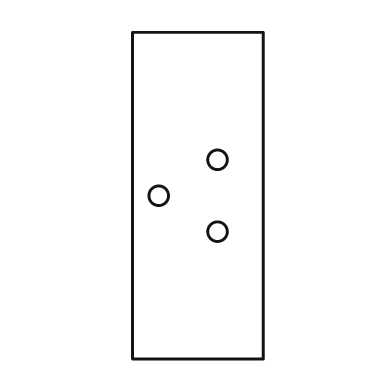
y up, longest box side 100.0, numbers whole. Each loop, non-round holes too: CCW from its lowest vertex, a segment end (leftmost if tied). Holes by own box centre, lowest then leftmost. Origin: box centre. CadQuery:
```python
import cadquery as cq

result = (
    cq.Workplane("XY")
    .moveTo(-20.0, -50.0)
    .lineTo(20.0, -50.0)
    .lineTo(20.0, 50.0)
    .lineTo(-20.0, 50.0)
    .close()
    .moveTo(6.0, -11.0)
    .circle(3.0)
    .moveTo(-12.0, 0.0)
    .circle(3.0)
    .moveTo(6.0, 11.0)
    .circle(3.0)
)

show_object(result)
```